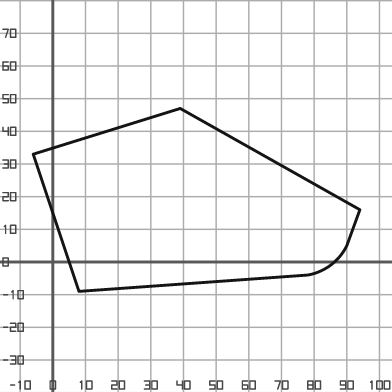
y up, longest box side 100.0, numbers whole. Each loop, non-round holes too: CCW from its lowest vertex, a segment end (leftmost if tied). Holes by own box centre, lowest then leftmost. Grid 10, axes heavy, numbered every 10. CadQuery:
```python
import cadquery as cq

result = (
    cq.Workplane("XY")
    .moveTo(8.0, -9.0)
    .lineTo(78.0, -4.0)
    .threePointArc((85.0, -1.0), (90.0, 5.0))
    .lineTo(94.0, 16.0)
    .lineTo(39.0, 47.0)
    .lineTo(-6.0, 33.0)
    .close()
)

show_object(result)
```